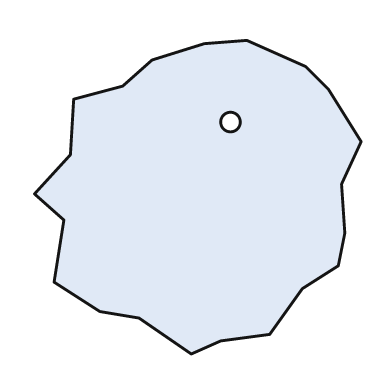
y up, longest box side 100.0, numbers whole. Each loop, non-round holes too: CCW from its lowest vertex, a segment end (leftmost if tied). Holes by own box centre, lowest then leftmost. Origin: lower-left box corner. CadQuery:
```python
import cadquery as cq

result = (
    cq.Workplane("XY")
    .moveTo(48.0, 0.0)
    .lineTo(57.0, 4.0)
    .lineTo(72.0, 6.0)
    .lineTo(82.0, 20.0)
    .lineTo(93.0, 27.0)
    .lineTo(95.0, 37.0)
    .lineTo(94.0, 52.0)
    .lineTo(100.0, 65.0)
    .lineTo(90.0, 81.0)
    .lineTo(83.0, 88.0)
    .lineTo(65.0, 96.0)
    .lineTo(52.0, 95.0)
    .lineTo(36.0, 90.0)
    .lineTo(27.0, 82.0)
    .lineTo(12.0, 78.0)
    .lineTo(11.0, 61.0)
    .lineTo(0.0, 49.0)
    .lineTo(9.0, 41.0)
    .lineTo(6.0, 22.0)
    .lineTo(20.0, 13.0)
    .lineTo(32.0, 11.0)
    .close()
    .moveTo(60.0, 71.0)
    .circle(3.0)
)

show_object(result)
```